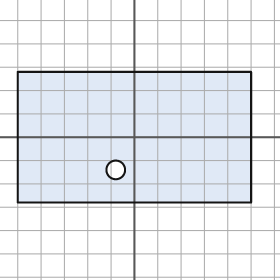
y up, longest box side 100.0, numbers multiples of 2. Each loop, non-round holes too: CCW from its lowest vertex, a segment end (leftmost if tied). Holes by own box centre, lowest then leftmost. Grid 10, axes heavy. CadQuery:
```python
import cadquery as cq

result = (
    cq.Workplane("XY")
    .moveTo(-50.0, -28.0)
    .lineTo(50.0, -28.0)
    .lineTo(50.0, 28.0)
    .lineTo(-50.0, 28.0)
    .close()
    .moveTo(-8.0, -14.0)
    .circle(4.0)
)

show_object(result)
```